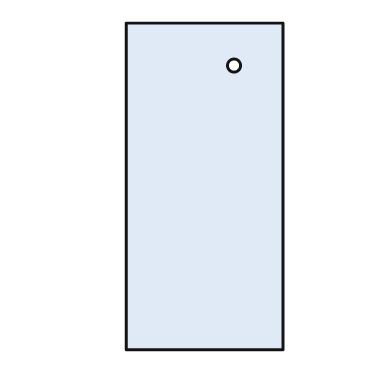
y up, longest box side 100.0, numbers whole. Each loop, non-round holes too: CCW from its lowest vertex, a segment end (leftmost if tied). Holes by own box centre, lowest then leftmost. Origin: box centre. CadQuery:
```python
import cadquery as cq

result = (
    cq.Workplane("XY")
    .moveTo(-24.0, -50.0)
    .lineTo(24.0, -50.0)
    .lineTo(24.0, 50.0)
    .lineTo(-24.0, 50.0)
    .close()
    .moveTo(9.0, 37.0)
    .circle(2.0)
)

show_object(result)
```